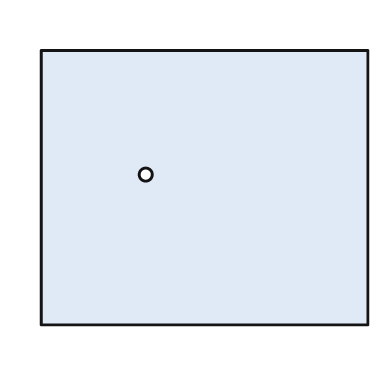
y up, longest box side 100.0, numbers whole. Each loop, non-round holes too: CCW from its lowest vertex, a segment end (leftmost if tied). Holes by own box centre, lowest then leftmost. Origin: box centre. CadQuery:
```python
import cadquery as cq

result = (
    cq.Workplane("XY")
    .moveTo(-50.0, -42.0)
    .lineTo(50.0, -42.0)
    .lineTo(50.0, 42.0)
    .lineTo(-50.0, 42.0)
    .close()
    .moveTo(-18.0, 4.0)
    .circle(2.0)
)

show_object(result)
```